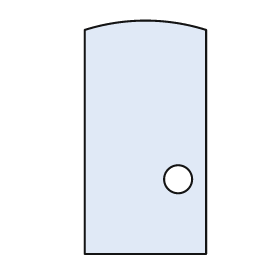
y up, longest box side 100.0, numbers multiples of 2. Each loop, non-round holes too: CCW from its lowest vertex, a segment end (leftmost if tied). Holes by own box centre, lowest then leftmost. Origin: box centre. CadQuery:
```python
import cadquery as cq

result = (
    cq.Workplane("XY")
    .moveTo(-26.0, -50.0)
    .lineTo(26.0, -50.0)
    .lineTo(26.0, 46.0)
    .threePointArc((0.0, 50.0), (-26.0, 46.0))
    .close()
    .moveTo(14.0, -18.0)
    .circle(6.0)
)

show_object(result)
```